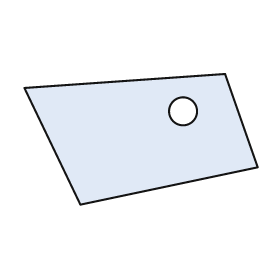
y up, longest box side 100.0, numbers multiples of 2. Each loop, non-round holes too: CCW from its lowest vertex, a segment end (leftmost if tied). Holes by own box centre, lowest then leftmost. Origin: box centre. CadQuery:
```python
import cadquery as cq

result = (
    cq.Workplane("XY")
    .moveTo(-26.0, -28.0)
    .lineTo(50.0, -12.0)
    .lineTo(36.0, 28.0)
    .lineTo(-50.0, 22.0)
    .close()
    .moveTo(18.0, 12.0)
    .circle(6.0)
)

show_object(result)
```